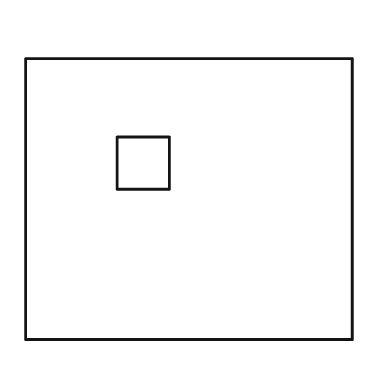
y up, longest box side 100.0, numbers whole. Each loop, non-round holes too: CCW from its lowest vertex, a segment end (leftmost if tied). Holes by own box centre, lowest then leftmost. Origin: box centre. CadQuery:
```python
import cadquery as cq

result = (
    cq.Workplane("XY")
    .moveTo(-50.0, -43.0)
    .lineTo(50.0, -43.0)
    .lineTo(50.0, 43.0)
    .lineTo(-50.0, 43.0)
    .close()
    .moveTo(-22.0, 3.0)
    .lineTo(-6.0, 3.0)
    .lineTo(-6.0, 19.0)
    .lineTo(-22.0, 19.0)
    .close()
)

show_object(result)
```